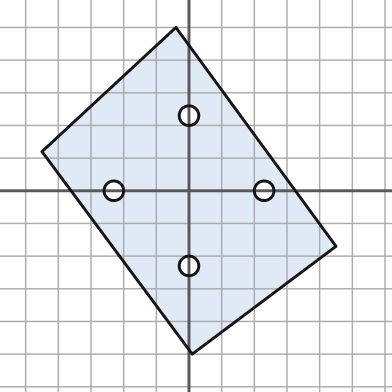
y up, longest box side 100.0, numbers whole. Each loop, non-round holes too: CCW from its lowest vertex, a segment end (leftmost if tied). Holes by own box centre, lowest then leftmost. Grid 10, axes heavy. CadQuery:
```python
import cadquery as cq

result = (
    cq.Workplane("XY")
    .moveTo(1.0, -50.0)
    .lineTo(45.0, -17.0)
    .lineTo(-4.0, 50.0)
    .lineTo(-45.0, 12.0)
    .close()
    .moveTo(0.0, -23.0)
    .circle(3.0)
    .moveTo(-23.0, 0.0)
    .circle(3.0)
    .moveTo(23.0, 0.0)
    .circle(3.0)
    .moveTo(0.0, 23.0)
    .circle(3.0)
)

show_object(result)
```